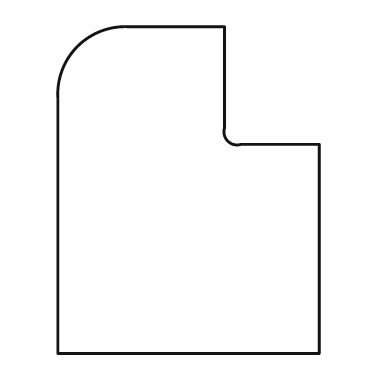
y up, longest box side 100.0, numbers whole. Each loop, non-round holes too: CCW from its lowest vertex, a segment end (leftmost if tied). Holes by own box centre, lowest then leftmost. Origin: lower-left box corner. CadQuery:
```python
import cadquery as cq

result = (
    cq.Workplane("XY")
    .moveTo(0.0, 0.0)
    .lineTo(80.0, 0.0)
    .lineTo(80.0, 64.0)
    .lineTo(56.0, 64.0)
    .threePointArc((52.0, 65.0), (51.0, 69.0))
    .lineTo(51.0, 100.0)
    .lineTo(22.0, 100.0)
    .threePointArc((6.0, 94.0), (0.0, 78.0))
    .close()
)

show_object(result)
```